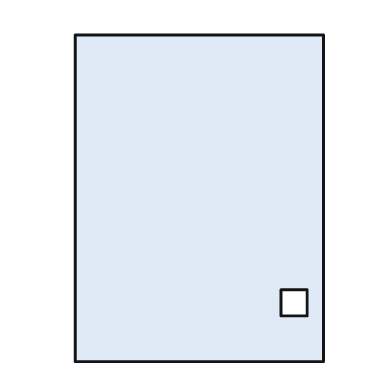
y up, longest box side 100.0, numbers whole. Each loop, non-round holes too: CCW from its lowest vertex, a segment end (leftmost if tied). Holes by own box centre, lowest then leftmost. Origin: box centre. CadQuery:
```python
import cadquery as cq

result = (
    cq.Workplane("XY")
    .moveTo(-38.0, -50.0)
    .lineTo(38.0, -50.0)
    .lineTo(38.0, 50.0)
    .lineTo(-38.0, 50.0)
    .close()
    .moveTo(25.0, -36.0)
    .lineTo(33.0, -36.0)
    .lineTo(33.0, -28.0)
    .lineTo(25.0, -28.0)
    .close()
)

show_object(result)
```